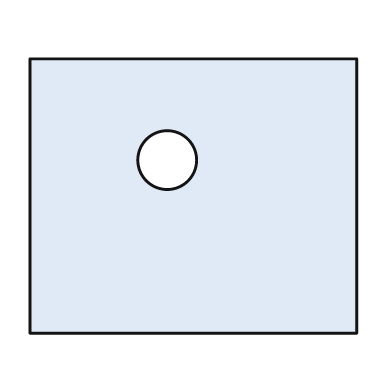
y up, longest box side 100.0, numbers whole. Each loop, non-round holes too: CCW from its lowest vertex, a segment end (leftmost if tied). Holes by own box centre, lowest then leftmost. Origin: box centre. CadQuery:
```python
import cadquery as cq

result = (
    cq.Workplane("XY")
    .moveTo(-50.0, -42.0)
    .lineTo(50.0, -42.0)
    .lineTo(50.0, 42.0)
    .lineTo(-50.0, 42.0)
    .close()
    .moveTo(-8.0, 11.0)
    .circle(9.0)
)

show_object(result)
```